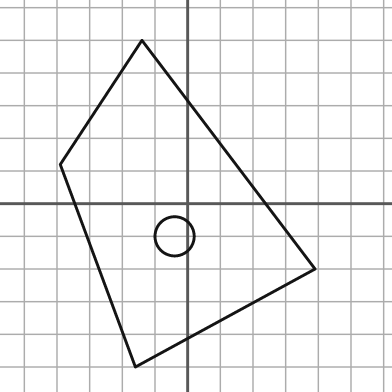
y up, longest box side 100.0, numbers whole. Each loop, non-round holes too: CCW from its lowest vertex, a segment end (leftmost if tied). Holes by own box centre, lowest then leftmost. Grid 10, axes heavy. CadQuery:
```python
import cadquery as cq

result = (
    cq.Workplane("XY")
    .moveTo(-16.0, -50.0)
    .lineTo(39.0, -20.0)
    .lineTo(-14.0, 50.0)
    .lineTo(-39.0, 12.0)
    .close()
    .moveTo(-4.0, -10.0)
    .circle(6.0)
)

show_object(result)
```